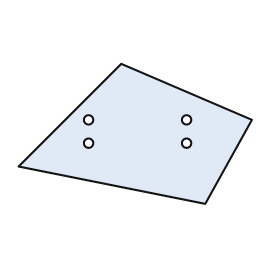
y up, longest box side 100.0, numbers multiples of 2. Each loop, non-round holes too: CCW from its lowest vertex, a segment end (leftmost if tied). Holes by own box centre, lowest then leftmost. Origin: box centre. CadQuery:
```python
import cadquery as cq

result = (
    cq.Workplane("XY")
    .moveTo(30.0, -30.0)
    .lineTo(50.0, 6.0)
    .lineTo(-6.0, 30.0)
    .lineTo(-50.0, -14.0)
    .close()
    .moveTo(-20.0, -4.0)
    .circle(2.0)
    .moveTo(22.0, -4.0)
    .circle(2.0)
    .moveTo(-20.0, 6.0)
    .circle(2.0)
    .moveTo(22.0, 6.0)
    .circle(2.0)
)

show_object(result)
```